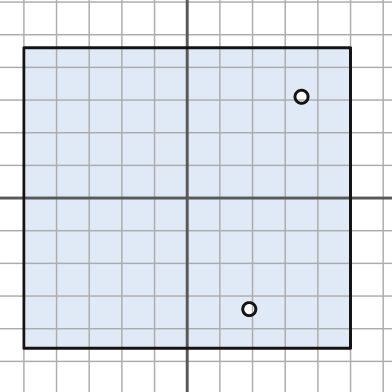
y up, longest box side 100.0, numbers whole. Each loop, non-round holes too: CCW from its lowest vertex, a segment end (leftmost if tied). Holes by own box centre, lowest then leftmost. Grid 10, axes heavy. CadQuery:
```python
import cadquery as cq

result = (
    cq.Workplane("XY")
    .moveTo(-50.0, -46.0)
    .lineTo(50.0, -46.0)
    .lineTo(50.0, 46.0)
    .lineTo(-50.0, 46.0)
    .close()
    .moveTo(19.0, -34.0)
    .circle(2.0)
    .moveTo(35.0, 31.0)
    .circle(2.0)
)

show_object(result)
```